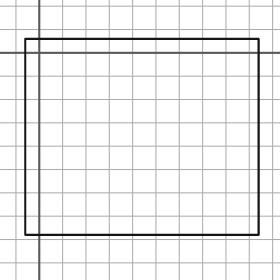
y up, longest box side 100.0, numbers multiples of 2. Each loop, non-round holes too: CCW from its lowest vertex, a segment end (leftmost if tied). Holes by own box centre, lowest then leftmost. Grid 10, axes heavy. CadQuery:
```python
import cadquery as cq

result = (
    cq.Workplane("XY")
    .moveTo(-6.0, -78.0)
    .lineTo(94.0, -78.0)
    .lineTo(94.0, 6.0)
    .lineTo(-6.0, 6.0)
    .close()
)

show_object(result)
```